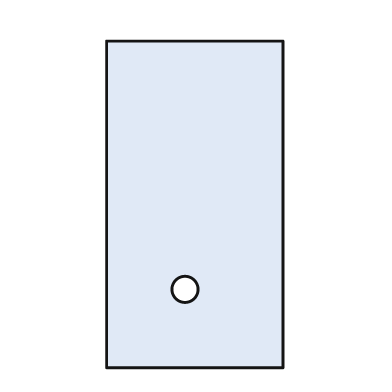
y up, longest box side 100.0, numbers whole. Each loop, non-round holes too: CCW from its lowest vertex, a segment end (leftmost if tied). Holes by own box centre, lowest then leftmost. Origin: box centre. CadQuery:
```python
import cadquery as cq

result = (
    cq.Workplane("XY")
    .moveTo(-27.0, -50.0)
    .lineTo(27.0, -50.0)
    .lineTo(27.0, 50.0)
    .lineTo(-27.0, 50.0)
    .close()
    .moveTo(-3.0, -26.0)
    .circle(4.0)
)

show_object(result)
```